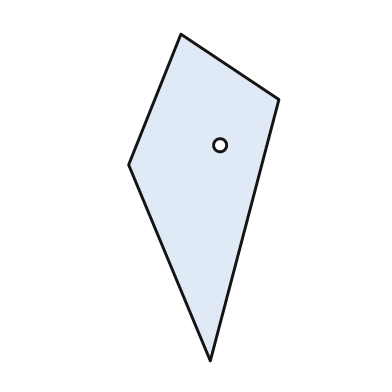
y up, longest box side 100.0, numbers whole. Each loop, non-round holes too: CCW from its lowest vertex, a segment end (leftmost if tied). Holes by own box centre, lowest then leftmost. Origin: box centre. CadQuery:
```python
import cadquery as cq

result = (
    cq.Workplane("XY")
    .moveTo(2.0, -50.0)
    .lineTo(23.0, 30.0)
    .lineTo(-7.0, 50.0)
    .lineTo(-23.0, 10.0)
    .close()
    .moveTo(5.0, 16.0)
    .circle(2.0)
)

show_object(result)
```